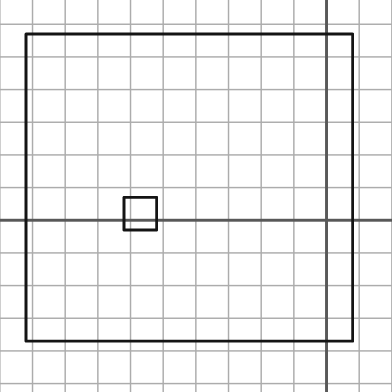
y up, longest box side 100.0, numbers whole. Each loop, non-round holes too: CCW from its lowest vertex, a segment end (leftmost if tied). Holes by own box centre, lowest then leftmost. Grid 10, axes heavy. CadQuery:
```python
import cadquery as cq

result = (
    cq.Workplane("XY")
    .moveTo(-92.0, -37.0)
    .lineTo(8.0, -37.0)
    .lineTo(8.0, 57.0)
    .lineTo(-92.0, 57.0)
    .close()
    .moveTo(-62.0, -3.0)
    .lineTo(-52.0, -3.0)
    .lineTo(-52.0, 7.0)
    .lineTo(-62.0, 7.0)
    .close()
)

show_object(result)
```